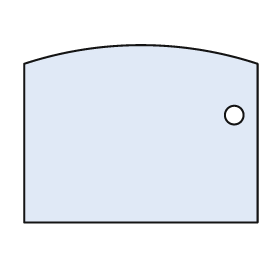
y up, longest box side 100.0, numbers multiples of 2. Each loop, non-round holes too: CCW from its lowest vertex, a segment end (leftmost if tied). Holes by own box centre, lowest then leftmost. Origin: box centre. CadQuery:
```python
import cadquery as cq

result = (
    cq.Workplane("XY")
    .moveTo(-50.0, -38.0)
    .lineTo(50.0, -38.0)
    .lineTo(50.0, 30.0)
    .threePointArc((0.0, 38.0), (-50.0, 30.0))
    .close()
    .moveTo(40.0, 8.0)
    .circle(4.0)
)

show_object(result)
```